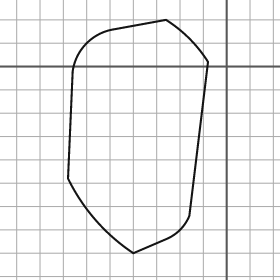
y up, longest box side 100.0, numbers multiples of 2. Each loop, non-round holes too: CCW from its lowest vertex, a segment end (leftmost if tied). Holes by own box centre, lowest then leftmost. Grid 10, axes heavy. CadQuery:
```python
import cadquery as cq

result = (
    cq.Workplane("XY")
    .moveTo(-40.0, -80.0)
    .lineTo(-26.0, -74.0)
    .threePointArc((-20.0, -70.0), (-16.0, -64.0))
    .lineTo(-8.0, 2.0)
    .threePointArc((-16.0, 12.0), (-26.0, 20.0))
    .lineTo(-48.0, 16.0)
    .threePointArc((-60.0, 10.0), (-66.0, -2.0))
    .lineTo(-68.0, -48.0)
    .threePointArc((-56.0, -66.0), (-40.0, -80.0))
    .close()
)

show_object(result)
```